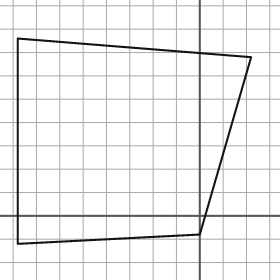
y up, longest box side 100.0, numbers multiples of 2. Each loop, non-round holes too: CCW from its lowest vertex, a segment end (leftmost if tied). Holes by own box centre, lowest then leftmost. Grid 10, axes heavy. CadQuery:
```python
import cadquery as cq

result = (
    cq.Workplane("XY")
    .moveTo(-78.0, -12.0)
    .lineTo(0.0, -8.0)
    .lineTo(22.0, 68.0)
    .lineTo(-78.0, 76.0)
    .close()
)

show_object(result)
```